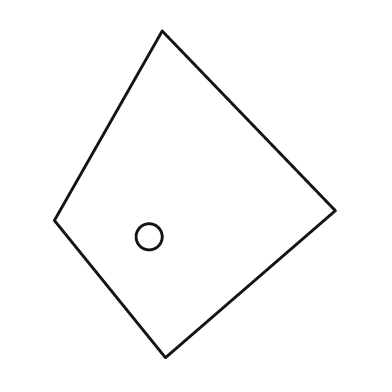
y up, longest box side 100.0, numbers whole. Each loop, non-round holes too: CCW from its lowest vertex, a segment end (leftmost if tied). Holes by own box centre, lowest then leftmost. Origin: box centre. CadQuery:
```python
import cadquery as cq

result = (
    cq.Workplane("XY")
    .moveTo(-9.0, -50.0)
    .lineTo(43.0, -5.0)
    .lineTo(-10.0, 50.0)
    .lineTo(-43.0, -8.0)
    .close()
    .moveTo(-14.0, -13.0)
    .circle(4.0)
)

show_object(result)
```